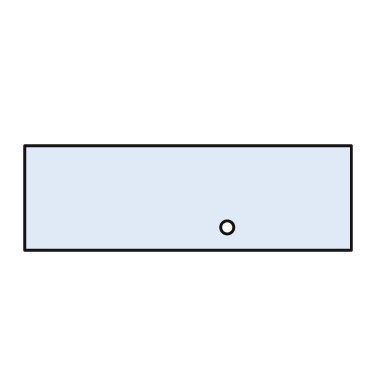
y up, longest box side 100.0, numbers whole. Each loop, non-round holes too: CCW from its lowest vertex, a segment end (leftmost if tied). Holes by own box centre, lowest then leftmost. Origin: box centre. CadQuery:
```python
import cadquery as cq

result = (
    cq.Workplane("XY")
    .moveTo(-50.0, -16.0)
    .lineTo(50.0, -16.0)
    .lineTo(50.0, 16.0)
    .lineTo(-50.0, 16.0)
    .close()
    .moveTo(12.0, -9.0)
    .circle(2.0)
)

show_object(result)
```